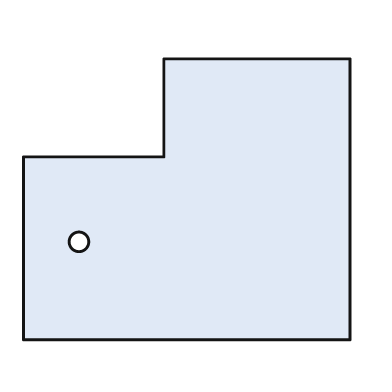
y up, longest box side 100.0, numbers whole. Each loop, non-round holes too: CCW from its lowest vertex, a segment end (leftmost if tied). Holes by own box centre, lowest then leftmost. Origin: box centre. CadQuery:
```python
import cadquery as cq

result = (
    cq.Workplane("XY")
    .moveTo(-50.0, -43.0)
    .lineTo(50.0, -43.0)
    .lineTo(50.0, 43.0)
    .lineTo(-7.0, 43.0)
    .lineTo(-7.0, 13.0)
    .lineTo(-50.0, 13.0)
    .close()
    .moveTo(-33.0, -13.0)
    .circle(3.0)
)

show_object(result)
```